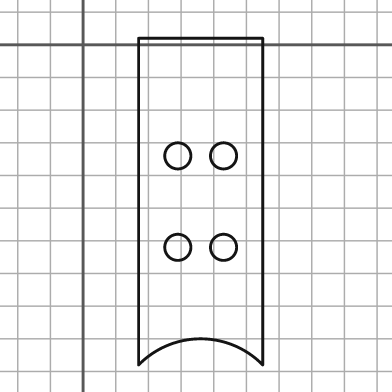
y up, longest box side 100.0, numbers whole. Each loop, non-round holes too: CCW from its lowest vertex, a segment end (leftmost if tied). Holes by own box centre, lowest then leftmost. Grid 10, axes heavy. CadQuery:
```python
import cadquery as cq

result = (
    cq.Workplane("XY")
    .moveTo(17.0, -98.0)
    .threePointArc((36.0, -90.0), (55.0, -98.0))
    .lineTo(55.0, 2.0)
    .lineTo(17.0, 2.0)
    .close()
    .moveTo(29.0, -62.0)
    .circle(4.0)
    .moveTo(43.0, -62.0)
    .circle(4.0)
    .moveTo(29.0, -34.0)
    .circle(4.0)
    .moveTo(43.0, -34.0)
    .circle(4.0)
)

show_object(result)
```